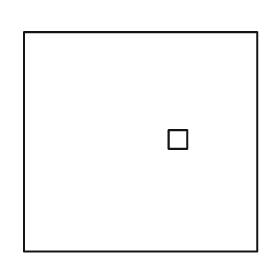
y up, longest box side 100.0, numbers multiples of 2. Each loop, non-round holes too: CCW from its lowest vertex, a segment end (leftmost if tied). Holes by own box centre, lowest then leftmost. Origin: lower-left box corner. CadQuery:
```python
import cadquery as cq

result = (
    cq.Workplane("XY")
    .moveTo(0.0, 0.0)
    .lineTo(100.0, 0.0)
    .lineTo(100.0, 94.0)
    .lineTo(0.0, 94.0)
    .close()
    .moveTo(62.0, 44.0)
    .lineTo(70.0, 44.0)
    .lineTo(70.0, 52.0)
    .lineTo(62.0, 52.0)
    .close()
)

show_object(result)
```